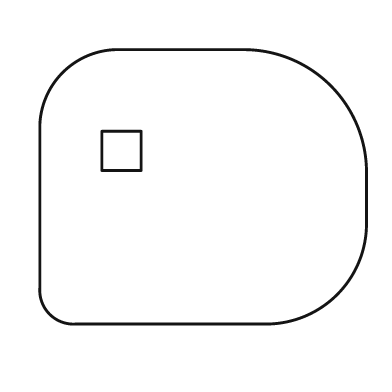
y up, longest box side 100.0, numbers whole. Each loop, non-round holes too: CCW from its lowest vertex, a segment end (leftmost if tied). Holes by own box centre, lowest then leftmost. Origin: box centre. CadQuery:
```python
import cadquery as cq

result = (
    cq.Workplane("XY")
    .moveTo(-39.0, -42.0)
    .lineTo(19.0, -42.0)
    .threePointArc((41.0, -33.0), (50.0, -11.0))
    .lineTo(50.0, 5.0)
    .threePointArc((39.0, 31.0), (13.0, 42.0))
    .lineTo(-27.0, 42.0)
    .threePointArc((-43.0, 35.0), (-50.0, 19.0))
    .lineTo(-50.0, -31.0)
    .threePointArc((-47.0, -39.0), (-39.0, -42.0))
    .close()
    .moveTo(-31.0, 5.0)
    .lineTo(-19.0, 5.0)
    .lineTo(-19.0, 17.0)
    .lineTo(-31.0, 17.0)
    .close()
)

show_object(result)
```